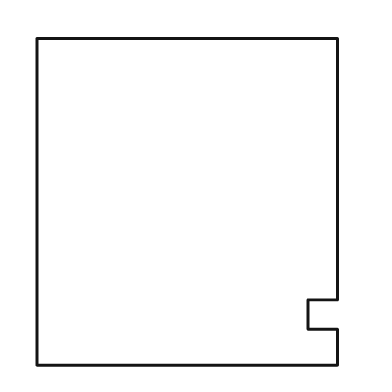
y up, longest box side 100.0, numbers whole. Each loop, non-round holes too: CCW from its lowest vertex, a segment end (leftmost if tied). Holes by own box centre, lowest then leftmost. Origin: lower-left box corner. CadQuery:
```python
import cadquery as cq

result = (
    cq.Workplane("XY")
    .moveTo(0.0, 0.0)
    .lineTo(92.0, 0.0)
    .lineTo(92.0, 11.0)
    .lineTo(83.0, 11.0)
    .lineTo(83.0, 20.0)
    .lineTo(92.0, 20.0)
    .lineTo(92.0, 100.0)
    .lineTo(0.0, 100.0)
    .close()
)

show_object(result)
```